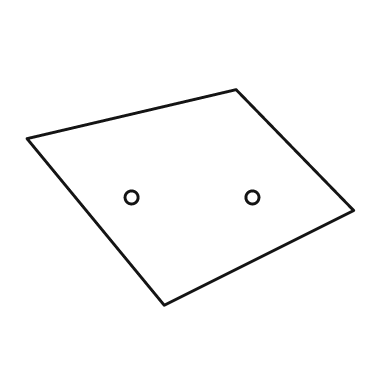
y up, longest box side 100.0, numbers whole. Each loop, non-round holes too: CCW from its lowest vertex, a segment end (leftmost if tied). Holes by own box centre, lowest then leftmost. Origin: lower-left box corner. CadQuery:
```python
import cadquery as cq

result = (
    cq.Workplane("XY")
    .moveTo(42.0, 0.0)
    .lineTo(100.0, 29.0)
    .lineTo(64.0, 66.0)
    .lineTo(0.0, 51.0)
    .close()
    .moveTo(32.0, 33.0)
    .circle(2.0)
    .moveTo(69.0, 33.0)
    .circle(2.0)
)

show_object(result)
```